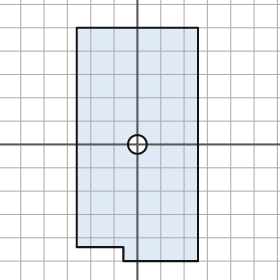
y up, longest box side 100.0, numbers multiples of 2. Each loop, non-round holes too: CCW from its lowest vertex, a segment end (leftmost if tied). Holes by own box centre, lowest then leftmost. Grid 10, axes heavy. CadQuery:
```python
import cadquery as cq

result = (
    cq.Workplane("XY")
    .moveTo(-6.0, -50.0)
    .lineTo(26.0, -50.0)
    .lineTo(26.0, 50.0)
    .lineTo(-26.0, 50.0)
    .lineTo(-26.0, -44.0)
    .lineTo(-6.0, -44.0)
    .close()
    .moveTo(0.0, 0.0)
    .circle(4.0)
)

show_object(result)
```